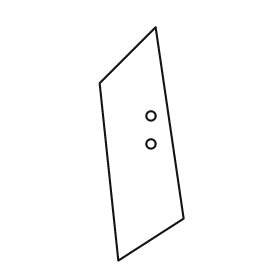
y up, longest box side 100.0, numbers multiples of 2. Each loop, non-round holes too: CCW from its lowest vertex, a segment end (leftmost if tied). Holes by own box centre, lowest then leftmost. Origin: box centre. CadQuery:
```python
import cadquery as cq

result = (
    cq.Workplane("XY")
    .moveTo(-10.0, -50.0)
    .lineTo(18.0, -32.0)
    .lineTo(6.0, 50.0)
    .lineTo(-18.0, 26.0)
    .close()
    .moveTo(4.0, 0.0)
    .circle(2.0)
    .moveTo(4.0, 12.0)
    .circle(2.0)
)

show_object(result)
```